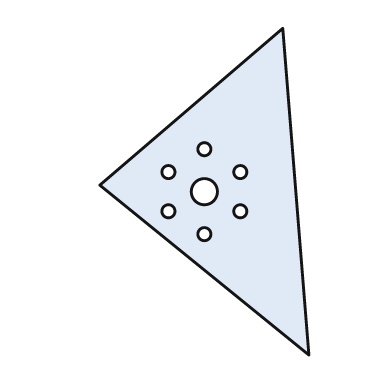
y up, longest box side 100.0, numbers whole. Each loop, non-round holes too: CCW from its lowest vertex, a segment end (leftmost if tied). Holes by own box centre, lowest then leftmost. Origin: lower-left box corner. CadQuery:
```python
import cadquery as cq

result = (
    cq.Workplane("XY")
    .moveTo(64.0, 0.0)
    .lineTo(56.0, 100.0)
    .lineTo(0.0, 52.0)
    .close()
    .moveTo(32.0, 37.0)
    .circle(2.0)
    .moveTo(21.0, 44.0)
    .circle(2.0)
    .moveTo(43.0, 44.0)
    .circle(2.0)
    .moveTo(32.0, 50.0)
    .circle(4.0)
    .moveTo(21.0, 56.0)
    .circle(2.0)
    .moveTo(43.0, 56.0)
    .circle(2.0)
    .moveTo(32.0, 63.0)
    .circle(2.0)
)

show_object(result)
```